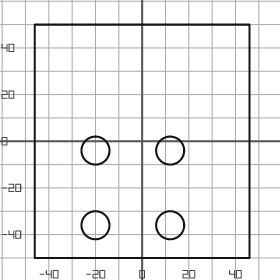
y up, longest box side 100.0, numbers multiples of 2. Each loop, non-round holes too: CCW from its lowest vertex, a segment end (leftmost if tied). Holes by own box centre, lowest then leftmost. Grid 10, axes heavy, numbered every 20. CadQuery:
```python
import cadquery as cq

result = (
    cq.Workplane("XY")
    .moveTo(-46.0, -50.0)
    .lineTo(46.0, -50.0)
    .lineTo(46.0, 50.0)
    .lineTo(-46.0, 50.0)
    .close()
    .moveTo(-20.0, -36.0)
    .circle(6.0)
    .moveTo(12.0, -36.0)
    .circle(6.0)
    .moveTo(-20.0, -4.0)
    .circle(6.0)
    .moveTo(12.0, -4.0)
    .circle(6.0)
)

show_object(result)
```